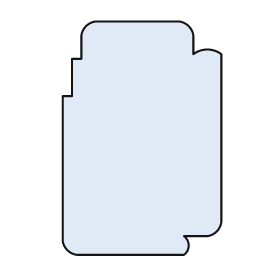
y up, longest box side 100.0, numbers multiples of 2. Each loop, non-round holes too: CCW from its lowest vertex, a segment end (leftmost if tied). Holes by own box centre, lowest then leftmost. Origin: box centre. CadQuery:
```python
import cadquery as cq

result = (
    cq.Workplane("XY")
    .moveTo(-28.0, -50.0)
    .lineTo(18.0, -50.0)
    .threePointArc((20.0, -46.0), (18.0, -42.0))
    .lineTo(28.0, -42.0)
    .threePointArc((32.0, -40.0), (34.0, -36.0))
    .lineTo(34.0, 36.0)
    .threePointArc((28.0, 38.0), (22.0, 36.0))
    .lineTo(22.0, 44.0)
    .threePointArc((20.0, 48.0), (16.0, 50.0))
    .lineTo(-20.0, 50.0)
    .threePointArc((-24.0, 48.0), (-26.0, 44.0))
    .lineTo(-26.0, 34.0)
    .lineTo(-30.0, 34.0)
    .lineTo(-30.0, 18.0)
    .lineTo(-34.0, 18.0)
    .lineTo(-34.0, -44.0)
    .threePointArc((-32.0, -48.0), (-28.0, -50.0))
    .close()
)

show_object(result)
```